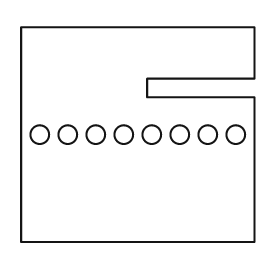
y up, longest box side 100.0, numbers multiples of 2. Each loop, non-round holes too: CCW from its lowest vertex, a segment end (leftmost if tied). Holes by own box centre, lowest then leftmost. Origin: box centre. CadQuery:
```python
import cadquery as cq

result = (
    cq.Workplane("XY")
    .moveTo(-50.0, -46.0)
    .lineTo(50.0, -46.0)
    .lineTo(50.0, 16.0)
    .lineTo(4.0, 16.0)
    .lineTo(4.0, 24.0)
    .lineTo(50.0, 24.0)
    .lineTo(50.0, 46.0)
    .lineTo(-50.0, 46.0)
    .close()
    .moveTo(-42.0, 0.0)
    .circle(4.0)
    .moveTo(-30.0, 0.0)
    .circle(4.0)
    .moveTo(-18.0, 0.0)
    .circle(4.0)
    .moveTo(-6.0, 0.0)
    .circle(4.0)
    .moveTo(6.0, 0.0)
    .circle(4.0)
    .moveTo(18.0, 0.0)
    .circle(4.0)
    .moveTo(30.0, 0.0)
    .circle(4.0)
    .moveTo(42.0, 0.0)
    .circle(4.0)
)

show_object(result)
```